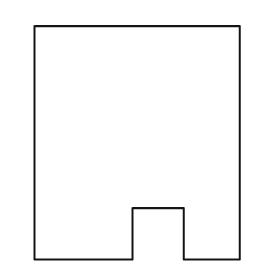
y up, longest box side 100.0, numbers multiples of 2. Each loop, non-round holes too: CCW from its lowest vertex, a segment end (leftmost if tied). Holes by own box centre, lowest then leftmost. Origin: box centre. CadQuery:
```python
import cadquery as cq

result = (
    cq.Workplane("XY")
    .moveTo(-44.0, -50.0)
    .lineTo(-2.0, -50.0)
    .lineTo(-2.0, -28.0)
    .lineTo(20.0, -28.0)
    .lineTo(20.0, -50.0)
    .lineTo(44.0, -50.0)
    .lineTo(44.0, 50.0)
    .lineTo(-44.0, 50.0)
    .close()
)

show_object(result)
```